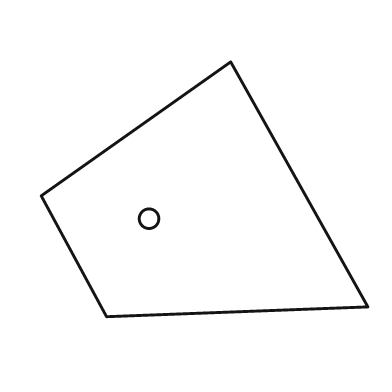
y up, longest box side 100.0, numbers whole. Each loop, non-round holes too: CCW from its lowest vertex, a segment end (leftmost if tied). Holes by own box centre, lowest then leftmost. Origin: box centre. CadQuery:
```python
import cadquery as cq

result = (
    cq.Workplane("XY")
    .moveTo(-30.0, -39.0)
    .lineTo(50.0, -36.0)
    .lineTo(8.0, 39.0)
    .lineTo(-50.0, -2.0)
    .close()
    .moveTo(-17.0, -9.0)
    .circle(3.0)
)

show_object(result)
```